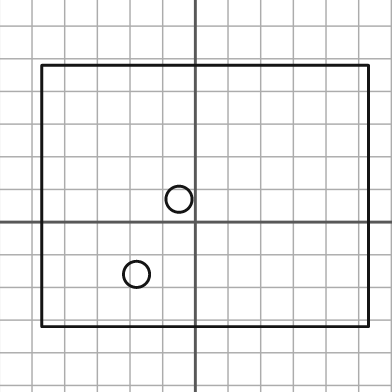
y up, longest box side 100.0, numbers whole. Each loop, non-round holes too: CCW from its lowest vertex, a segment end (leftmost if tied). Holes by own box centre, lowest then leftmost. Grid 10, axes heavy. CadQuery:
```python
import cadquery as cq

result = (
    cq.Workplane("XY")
    .moveTo(-47.0, -32.0)
    .lineTo(53.0, -32.0)
    .lineTo(53.0, 48.0)
    .lineTo(-47.0, 48.0)
    .close()
    .moveTo(-18.0, -16.0)
    .circle(4.0)
    .moveTo(-5.0, 7.0)
    .circle(4.0)
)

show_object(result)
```